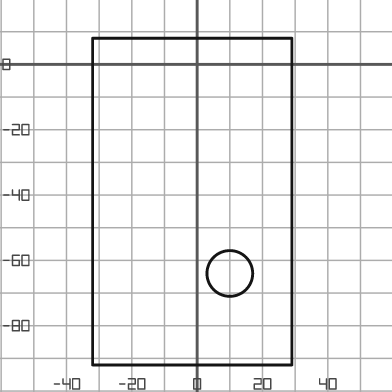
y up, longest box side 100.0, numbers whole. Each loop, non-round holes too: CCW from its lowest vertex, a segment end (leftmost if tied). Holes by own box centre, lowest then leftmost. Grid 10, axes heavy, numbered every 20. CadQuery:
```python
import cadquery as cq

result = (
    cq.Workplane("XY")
    .moveTo(-32.0, -92.0)
    .lineTo(29.0, -92.0)
    .lineTo(29.0, 8.0)
    .lineTo(-32.0, 8.0)
    .close()
    .moveTo(10.0, -64.0)
    .circle(7.0)
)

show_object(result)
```